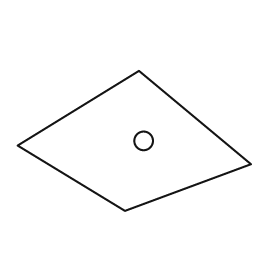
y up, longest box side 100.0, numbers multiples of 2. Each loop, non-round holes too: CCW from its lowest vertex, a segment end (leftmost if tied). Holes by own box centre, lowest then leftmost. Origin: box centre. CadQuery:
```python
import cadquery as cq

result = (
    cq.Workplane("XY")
    .moveTo(-4.0, -30.0)
    .lineTo(50.0, -10.0)
    .lineTo(2.0, 30.0)
    .lineTo(-50.0, -2.0)
    .close()
    .moveTo(4.0, 0.0)
    .circle(4.0)
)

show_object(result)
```